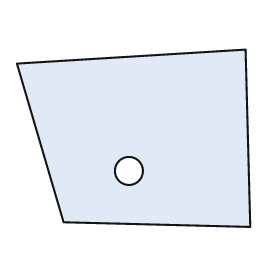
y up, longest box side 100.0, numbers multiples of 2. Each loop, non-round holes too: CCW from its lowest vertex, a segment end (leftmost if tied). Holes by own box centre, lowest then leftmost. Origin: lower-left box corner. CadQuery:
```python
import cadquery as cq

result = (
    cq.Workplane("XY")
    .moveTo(100.0, 0.0)
    .lineTo(98.0, 76.0)
    .lineTo(0.0, 70.0)
    .lineTo(20.0, 2.0)
    .close()
    .moveTo(48.0, 24.0)
    .circle(6.0)
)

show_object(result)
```